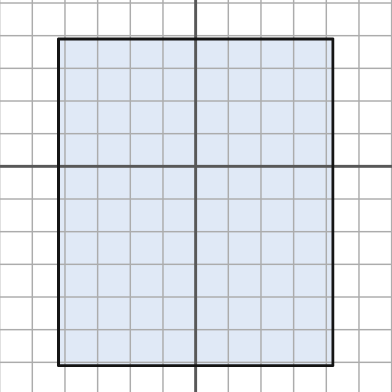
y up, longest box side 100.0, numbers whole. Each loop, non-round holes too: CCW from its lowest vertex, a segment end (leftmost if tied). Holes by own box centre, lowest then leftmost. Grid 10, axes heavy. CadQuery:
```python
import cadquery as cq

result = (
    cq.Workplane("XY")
    .moveTo(-42.0, -61.0)
    .lineTo(42.0, -61.0)
    .lineTo(42.0, 39.0)
    .lineTo(-42.0, 39.0)
    .close()
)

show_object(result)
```